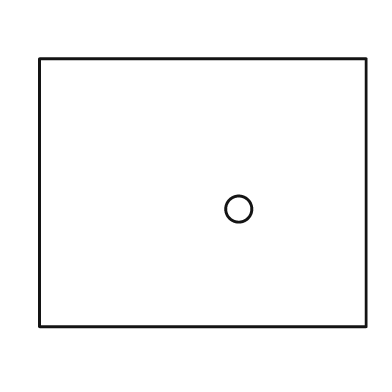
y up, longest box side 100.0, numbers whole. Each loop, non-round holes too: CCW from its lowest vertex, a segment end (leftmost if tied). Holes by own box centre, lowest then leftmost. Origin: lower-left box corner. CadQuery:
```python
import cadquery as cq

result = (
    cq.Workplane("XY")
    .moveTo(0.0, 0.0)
    .lineTo(100.0, 0.0)
    .lineTo(100.0, 82.0)
    .lineTo(0.0, 82.0)
    .close()
    .moveTo(61.0, 36.0)
    .circle(4.0)
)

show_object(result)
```